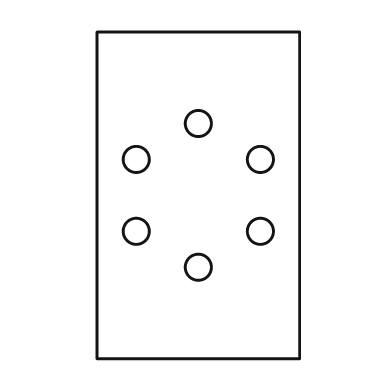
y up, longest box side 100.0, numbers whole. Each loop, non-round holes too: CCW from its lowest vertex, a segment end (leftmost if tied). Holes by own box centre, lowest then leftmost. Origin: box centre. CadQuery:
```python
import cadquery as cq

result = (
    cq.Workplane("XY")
    .moveTo(-31.0, -50.0)
    .lineTo(31.0, -50.0)
    .lineTo(31.0, 50.0)
    .lineTo(-31.0, 50.0)
    .close()
    .moveTo(0.0, -22.0)
    .circle(4.0)
    .moveTo(-19.0, -11.0)
    .circle(4.0)
    .moveTo(19.0, -11.0)
    .circle(4.0)
    .moveTo(-19.0, 11.0)
    .circle(4.0)
    .moveTo(19.0, 11.0)
    .circle(4.0)
    .moveTo(0.0, 22.0)
    .circle(4.0)
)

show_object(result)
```